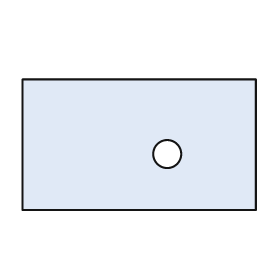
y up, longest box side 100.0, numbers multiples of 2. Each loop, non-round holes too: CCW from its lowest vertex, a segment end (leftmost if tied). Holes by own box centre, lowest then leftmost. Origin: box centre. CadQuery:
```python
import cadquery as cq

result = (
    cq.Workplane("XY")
    .moveTo(-50.0, -28.0)
    .lineTo(50.0, -28.0)
    .lineTo(50.0, 28.0)
    .lineTo(-50.0, 28.0)
    .close()
    .moveTo(12.0, -4.0)
    .circle(6.0)
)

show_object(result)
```